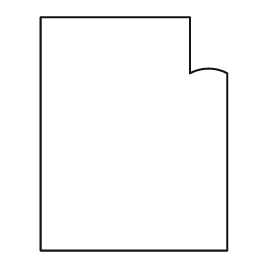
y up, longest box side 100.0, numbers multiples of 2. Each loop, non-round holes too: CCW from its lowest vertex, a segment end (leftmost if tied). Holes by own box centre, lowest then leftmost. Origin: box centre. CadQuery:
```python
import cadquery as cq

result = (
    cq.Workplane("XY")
    .moveTo(-40.0, -50.0)
    .lineTo(40.0, -50.0)
    .lineTo(40.0, 26.0)
    .threePointArc((32.0, 28.0), (24.0, 26.0))
    .lineTo(24.0, 50.0)
    .lineTo(-40.0, 50.0)
    .close()
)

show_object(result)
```